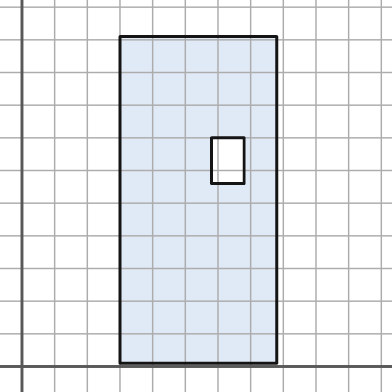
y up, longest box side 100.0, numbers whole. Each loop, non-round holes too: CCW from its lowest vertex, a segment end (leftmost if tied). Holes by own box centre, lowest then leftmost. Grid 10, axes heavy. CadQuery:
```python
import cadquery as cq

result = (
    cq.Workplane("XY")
    .moveTo(30.0, 1.0)
    .lineTo(78.0, 1.0)
    .lineTo(78.0, 101.0)
    .lineTo(30.0, 101.0)
    .close()
    .moveTo(58.0, 56.0)
    .lineTo(68.0, 56.0)
    .lineTo(68.0, 70.0)
    .lineTo(58.0, 70.0)
    .close()
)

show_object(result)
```